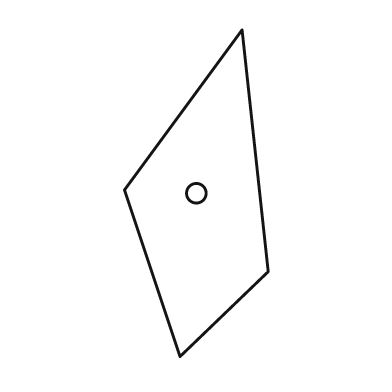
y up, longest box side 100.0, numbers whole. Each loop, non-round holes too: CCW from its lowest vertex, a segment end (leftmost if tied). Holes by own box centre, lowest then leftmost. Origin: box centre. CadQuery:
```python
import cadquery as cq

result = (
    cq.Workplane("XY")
    .moveTo(-5.0, -50.0)
    .lineTo(22.0, -24.0)
    .lineTo(14.0, 50.0)
    .lineTo(-22.0, 1.0)
    .close()
    .moveTo(0.0, 0.0)
    .circle(3.0)
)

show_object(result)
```